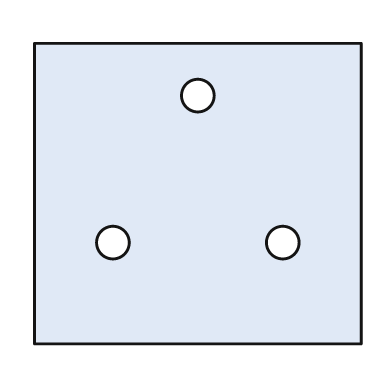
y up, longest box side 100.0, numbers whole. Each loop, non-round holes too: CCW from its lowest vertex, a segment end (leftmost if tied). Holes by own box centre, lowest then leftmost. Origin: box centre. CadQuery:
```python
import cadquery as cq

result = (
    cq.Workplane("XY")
    .moveTo(-50.0, -46.0)
    .lineTo(50.0, -46.0)
    .lineTo(50.0, 46.0)
    .lineTo(-50.0, 46.0)
    .close()
    .moveTo(-26.0, -15.0)
    .circle(5.0)
    .moveTo(26.0, -15.0)
    .circle(5.0)
    .moveTo(0.0, 30.0)
    .circle(5.0)
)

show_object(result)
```